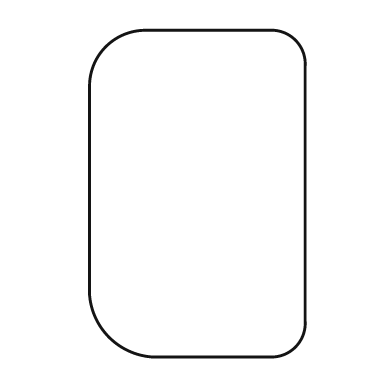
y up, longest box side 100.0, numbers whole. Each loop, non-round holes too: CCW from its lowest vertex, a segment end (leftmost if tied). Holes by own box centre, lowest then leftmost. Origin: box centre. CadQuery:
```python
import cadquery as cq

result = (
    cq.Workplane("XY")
    .moveTo(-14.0, -50.0)
    .lineTo(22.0, -50.0)
    .threePointArc((30.0, -47.0), (33.0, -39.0))
    .lineTo(33.0, 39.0)
    .threePointArc((30.0, 47.0), (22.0, 50.0))
    .lineTo(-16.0, 50.0)
    .threePointArc((-28.0, 45.0), (-33.0, 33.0))
    .lineTo(-33.0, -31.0)
    .threePointArc((-27.0, -44.0), (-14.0, -50.0))
    .close()
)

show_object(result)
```